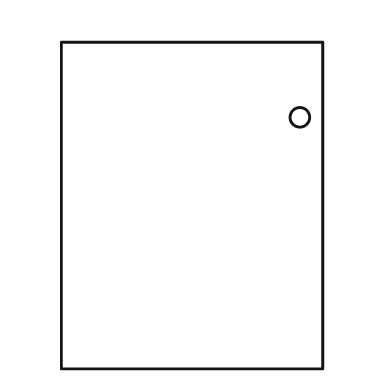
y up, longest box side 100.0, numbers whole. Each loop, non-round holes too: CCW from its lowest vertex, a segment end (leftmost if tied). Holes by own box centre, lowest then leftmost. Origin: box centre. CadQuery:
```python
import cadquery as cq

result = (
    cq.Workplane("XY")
    .moveTo(-40.0, -50.0)
    .lineTo(40.0, -50.0)
    .lineTo(40.0, 50.0)
    .lineTo(-40.0, 50.0)
    .close()
    .moveTo(33.0, 27.0)
    .circle(3.0)
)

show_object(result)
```